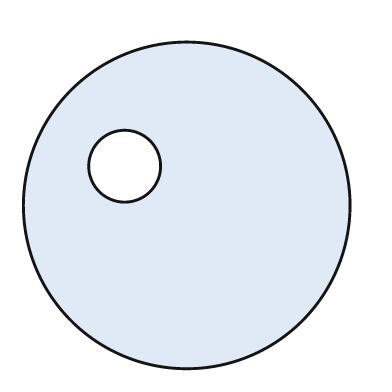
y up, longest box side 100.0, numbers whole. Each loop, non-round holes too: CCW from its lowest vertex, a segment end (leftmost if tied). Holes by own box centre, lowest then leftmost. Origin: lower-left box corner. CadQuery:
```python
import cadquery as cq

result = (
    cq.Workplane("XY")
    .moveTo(50.0, 50.0)
    .circle(50.0)
    .moveTo(31.0, 62.0)
    .circle(11.0)
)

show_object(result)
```